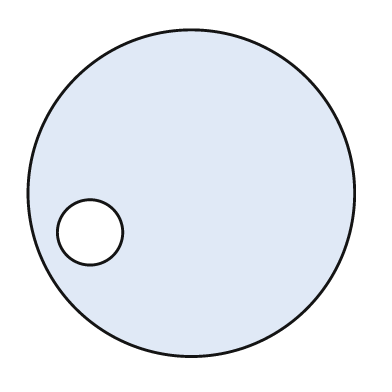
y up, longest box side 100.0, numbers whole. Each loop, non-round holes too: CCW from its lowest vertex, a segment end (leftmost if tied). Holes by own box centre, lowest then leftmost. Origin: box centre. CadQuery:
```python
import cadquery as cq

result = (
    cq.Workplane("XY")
    .moveTo(0.0, 0.0)
    .circle(50.0)
    .moveTo(-31.0, -12.0)
    .circle(10.0)
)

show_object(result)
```